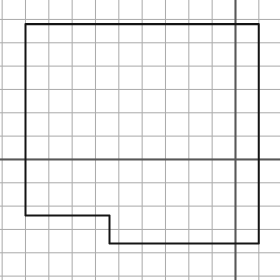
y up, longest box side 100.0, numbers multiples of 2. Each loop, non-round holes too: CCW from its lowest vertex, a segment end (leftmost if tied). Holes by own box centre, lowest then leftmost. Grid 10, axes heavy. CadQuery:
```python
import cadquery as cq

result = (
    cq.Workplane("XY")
    .moveTo(-54.0, -36.0)
    .lineTo(10.0, -36.0)
    .lineTo(10.0, 58.0)
    .lineTo(-90.0, 58.0)
    .lineTo(-90.0, -24.0)
    .lineTo(-54.0, -24.0)
    .close()
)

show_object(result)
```